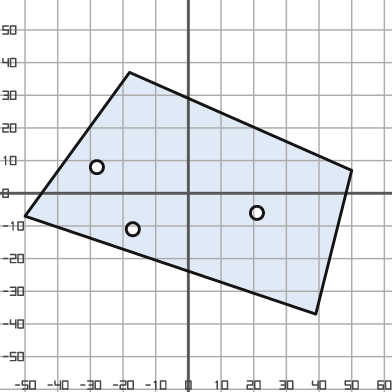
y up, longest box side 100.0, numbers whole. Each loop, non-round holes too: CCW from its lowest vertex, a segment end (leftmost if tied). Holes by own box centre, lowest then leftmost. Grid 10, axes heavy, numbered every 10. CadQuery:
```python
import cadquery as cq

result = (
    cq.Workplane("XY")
    .moveTo(39.0, -37.0)
    .lineTo(50.0, 7.0)
    .lineTo(-18.0, 37.0)
    .lineTo(-50.0, -7.0)
    .close()
    .moveTo(-17.0, -11.0)
    .circle(2.0)
    .moveTo(21.0, -6.0)
    .circle(2.0)
    .moveTo(-28.0, 8.0)
    .circle(2.0)
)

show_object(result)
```